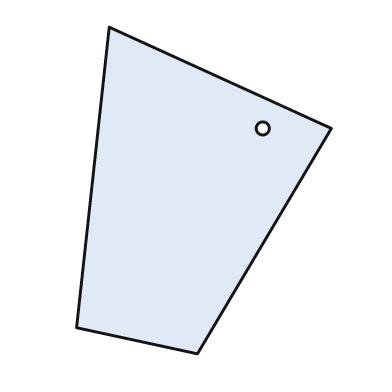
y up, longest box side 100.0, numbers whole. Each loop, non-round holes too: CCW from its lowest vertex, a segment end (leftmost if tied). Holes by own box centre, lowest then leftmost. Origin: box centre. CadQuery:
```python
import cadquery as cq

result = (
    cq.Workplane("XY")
    .moveTo(-2.0, -50.0)
    .lineTo(39.0, 19.0)
    .lineTo(-29.0, 50.0)
    .lineTo(-39.0, -42.0)
    .close()
    .moveTo(18.0, 19.0)
    .circle(2.0)
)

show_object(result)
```